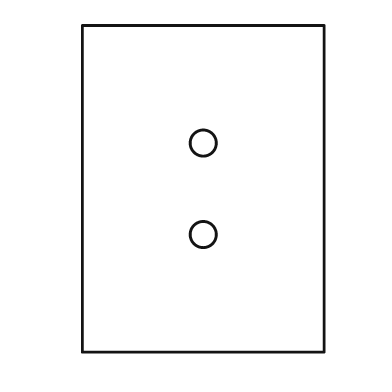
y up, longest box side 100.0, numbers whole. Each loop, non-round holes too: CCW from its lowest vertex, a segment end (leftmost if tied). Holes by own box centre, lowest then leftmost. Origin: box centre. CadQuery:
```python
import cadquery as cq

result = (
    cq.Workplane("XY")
    .moveTo(-37.0, -50.0)
    .lineTo(37.0, -50.0)
    .lineTo(37.0, 50.0)
    .lineTo(-37.0, 50.0)
    .close()
    .moveTo(0.0, -14.0)
    .circle(4.0)
    .moveTo(0.0, 14.0)
    .circle(4.0)
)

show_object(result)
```